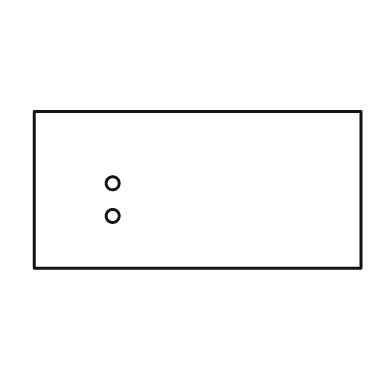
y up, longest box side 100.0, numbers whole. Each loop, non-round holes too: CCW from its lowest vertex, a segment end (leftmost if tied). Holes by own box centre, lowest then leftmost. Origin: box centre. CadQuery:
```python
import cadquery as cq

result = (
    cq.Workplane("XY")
    .moveTo(-50.0, -24.0)
    .lineTo(50.0, -24.0)
    .lineTo(50.0, 24.0)
    .lineTo(-50.0, 24.0)
    .close()
    .moveTo(-26.0, -8.0)
    .circle(2.0)
    .moveTo(-26.0, 2.0)
    .circle(2.0)
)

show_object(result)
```